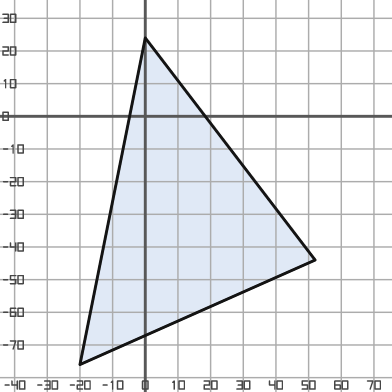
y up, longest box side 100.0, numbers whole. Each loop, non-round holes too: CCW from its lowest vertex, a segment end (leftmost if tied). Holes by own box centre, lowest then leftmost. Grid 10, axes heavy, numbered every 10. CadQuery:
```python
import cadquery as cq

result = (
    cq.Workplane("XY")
    .moveTo(-20.0, -76.0)
    .lineTo(52.0, -44.0)
    .lineTo(0.0, 24.0)
    .close()
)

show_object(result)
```